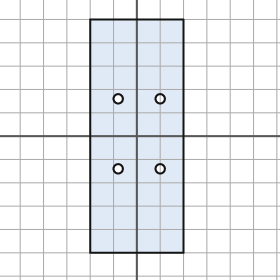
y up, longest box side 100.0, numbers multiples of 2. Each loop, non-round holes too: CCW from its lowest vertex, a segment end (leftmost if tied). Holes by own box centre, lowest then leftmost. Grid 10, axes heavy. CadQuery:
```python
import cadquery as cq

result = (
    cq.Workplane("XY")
    .moveTo(-20.0, -50.0)
    .lineTo(20.0, -50.0)
    .lineTo(20.0, 50.0)
    .lineTo(-20.0, 50.0)
    .close()
    .moveTo(-8.0, -14.0)
    .circle(2.0)
    .moveTo(10.0, -14.0)
    .circle(2.0)
    .moveTo(-8.0, 16.0)
    .circle(2.0)
    .moveTo(10.0, 16.0)
    .circle(2.0)
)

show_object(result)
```